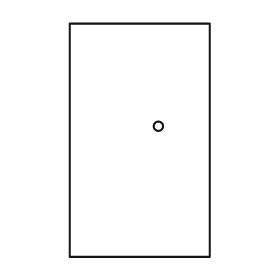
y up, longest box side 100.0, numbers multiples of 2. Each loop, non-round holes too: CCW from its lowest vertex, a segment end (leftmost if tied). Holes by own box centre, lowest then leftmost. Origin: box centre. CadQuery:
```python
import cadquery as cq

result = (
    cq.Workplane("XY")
    .moveTo(-30.0, -50.0)
    .lineTo(30.0, -50.0)
    .lineTo(30.0, 50.0)
    .lineTo(-30.0, 50.0)
    .close()
    .moveTo(8.0, 6.0)
    .circle(2.0)
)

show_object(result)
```